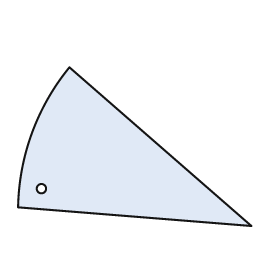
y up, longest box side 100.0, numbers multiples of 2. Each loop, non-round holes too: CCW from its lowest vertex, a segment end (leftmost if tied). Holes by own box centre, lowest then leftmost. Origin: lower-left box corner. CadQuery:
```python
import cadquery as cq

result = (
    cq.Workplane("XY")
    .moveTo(100.0, 0.0)
    .lineTo(22.0, 68.0)
    .threePointArc((6.0, 40.0), (0.0, 8.0))
    .close()
    .moveTo(10.0, 16.0)
    .circle(2.0)
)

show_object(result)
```